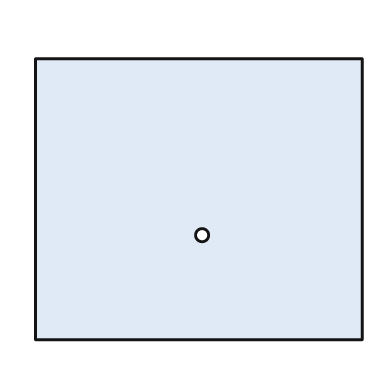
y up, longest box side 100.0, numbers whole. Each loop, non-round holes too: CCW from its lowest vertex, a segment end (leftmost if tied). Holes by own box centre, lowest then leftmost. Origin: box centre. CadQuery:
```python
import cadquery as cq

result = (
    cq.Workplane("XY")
    .moveTo(-50.0, -43.0)
    .lineTo(50.0, -43.0)
    .lineTo(50.0, 43.0)
    .lineTo(-50.0, 43.0)
    .close()
    .moveTo(1.0, -11.0)
    .circle(2.0)
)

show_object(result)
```